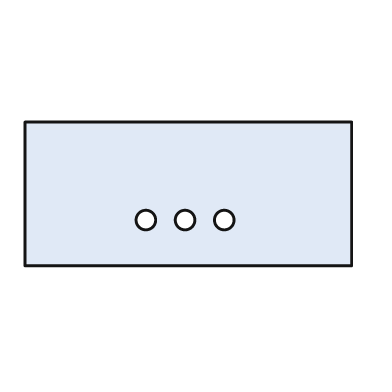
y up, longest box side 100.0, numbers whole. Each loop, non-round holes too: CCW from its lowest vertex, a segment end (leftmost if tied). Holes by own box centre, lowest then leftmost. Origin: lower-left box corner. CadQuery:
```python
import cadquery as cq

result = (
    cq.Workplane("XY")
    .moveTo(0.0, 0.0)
    .lineTo(100.0, 0.0)
    .lineTo(100.0, 44.0)
    .lineTo(0.0, 44.0)
    .close()
    .moveTo(37.0, 14.0)
    .circle(3.0)
    .moveTo(49.0, 14.0)
    .circle(3.0)
    .moveTo(61.0, 14.0)
    .circle(3.0)
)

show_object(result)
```